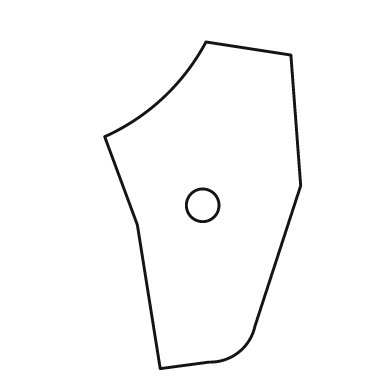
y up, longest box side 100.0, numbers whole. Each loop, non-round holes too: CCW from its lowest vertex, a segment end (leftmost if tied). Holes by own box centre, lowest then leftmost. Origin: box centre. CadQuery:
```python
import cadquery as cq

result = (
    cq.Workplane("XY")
    .moveTo(-13.0, -50.0)
    .lineTo(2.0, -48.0)
    .threePointArc((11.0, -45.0), (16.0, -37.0))
    .lineTo(30.0, 6.0)
    .lineTo(27.0, 46.0)
    .lineTo(1.0, 50.0)
    .threePointArc((-12.0, 33.0), (-30.0, 21.0))
    .lineTo(-20.0, -6.0)
    .close()
    .moveTo(0.0, 0.0)
    .circle(5.0)
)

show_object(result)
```